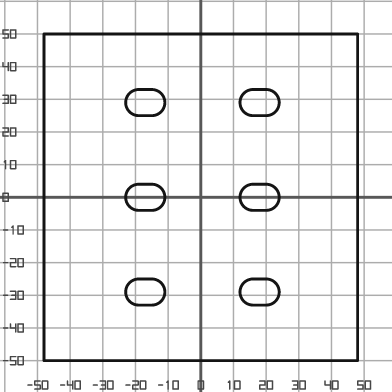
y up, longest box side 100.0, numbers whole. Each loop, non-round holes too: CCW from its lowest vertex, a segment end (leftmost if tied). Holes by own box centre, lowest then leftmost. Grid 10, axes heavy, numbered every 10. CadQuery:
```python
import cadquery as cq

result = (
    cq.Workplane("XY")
    .moveTo(-48.0, -50.0)
    .lineTo(48.0, -50.0)
    .lineTo(48.0, 50.0)
    .lineTo(-48.0, 50.0)
    .close()
    .moveTo(-19.0, -33.0)
    .lineTo(-15.0, -33.0)
    .threePointArc((-11.0, -29.0), (-15.0, -25.0))
    .lineTo(-19.0, -25.0)
    .threePointArc((-23.0, -29.0), (-19.0, -33.0))
    .close()
    .moveTo(16.0, -33.0)
    .lineTo(20.0, -33.0)
    .threePointArc((24.0, -29.0), (20.0, -25.0))
    .lineTo(16.0, -25.0)
    .threePointArc((12.0, -29.0), (16.0, -33.0))
    .close()
    .moveTo(-19.0, -4.0)
    .lineTo(-15.0, -4.0)
    .threePointArc((-11.0, 0.0), (-15.0, 4.0))
    .lineTo(-19.0, 4.0)
    .threePointArc((-23.0, 0.0), (-19.0, -4.0))
    .close()
    .moveTo(16.0, -4.0)
    .lineTo(20.0, -4.0)
    .threePointArc((24.0, 0.0), (20.0, 4.0))
    .lineTo(16.0, 4.0)
    .threePointArc((12.0, 0.0), (16.0, -4.0))
    .close()
    .moveTo(-19.0, 25.0)
    .lineTo(-15.0, 25.0)
    .threePointArc((-11.0, 29.0), (-15.0, 33.0))
    .lineTo(-19.0, 33.0)
    .threePointArc((-23.0, 29.0), (-19.0, 25.0))
    .close()
    .moveTo(16.0, 25.0)
    .lineTo(20.0, 25.0)
    .threePointArc((24.0, 29.0), (20.0, 33.0))
    .lineTo(16.0, 33.0)
    .threePointArc((12.0, 29.0), (16.0, 25.0))
    .close()
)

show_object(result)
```